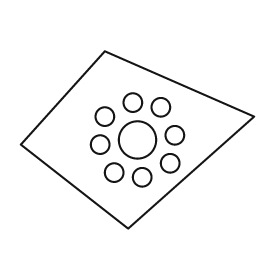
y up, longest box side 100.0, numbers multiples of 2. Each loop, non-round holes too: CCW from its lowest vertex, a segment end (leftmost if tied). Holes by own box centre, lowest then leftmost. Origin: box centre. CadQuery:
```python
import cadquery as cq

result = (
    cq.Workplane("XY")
    .moveTo(-4.0, -38.0)
    .lineTo(50.0, 10.0)
    .lineTo(-14.0, 38.0)
    .lineTo(-50.0, -2.0)
    .close()
    .moveTo(2.0, -16.0)
    .circle(4.0)
    .moveTo(-10.0, -14.0)
    .circle(4.0)
    .moveTo(14.0, -10.0)
    .circle(4.0)
    .moveTo(-16.0, -2.0)
    .circle(4.0)
    .moveTo(0.0, 0.0)
    .circle(8.0)
    .moveTo(16.0, 2.0)
    .circle(4.0)
    .moveTo(-14.0, 10.0)
    .circle(4.0)
    .moveTo(10.0, 14.0)
    .circle(4.0)
    .moveTo(-2.0, 16.0)
    .circle(4.0)
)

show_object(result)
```